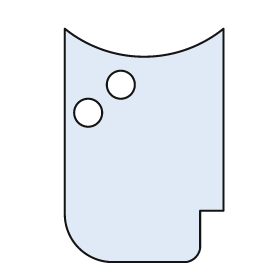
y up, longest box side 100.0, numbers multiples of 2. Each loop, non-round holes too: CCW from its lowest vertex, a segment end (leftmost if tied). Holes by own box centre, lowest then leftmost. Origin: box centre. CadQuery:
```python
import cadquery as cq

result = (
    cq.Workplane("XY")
    .moveTo(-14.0, -50.0)
    .lineTo(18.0, -50.0)
    .threePointArc((22.0, -48.0), (24.0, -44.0))
    .lineTo(24.0, -28.0)
    .lineTo(34.0, -28.0)
    .lineTo(34.0, 50.0)
    .threePointArc((0.0, 38.0), (-34.0, 50.0))
    .lineTo(-34.0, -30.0)
    .threePointArc((-28.0, -44.0), (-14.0, -50.0))
    .close()
    .moveTo(-24.0, 14.0)
    .circle(6.0)
    .moveTo(-10.0, 26.0)
    .circle(6.0)
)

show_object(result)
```